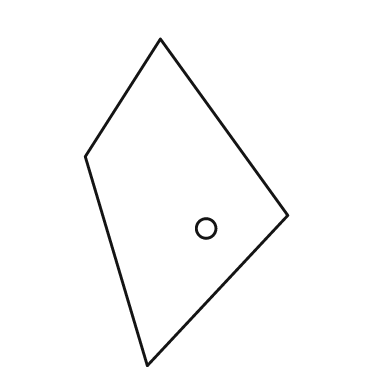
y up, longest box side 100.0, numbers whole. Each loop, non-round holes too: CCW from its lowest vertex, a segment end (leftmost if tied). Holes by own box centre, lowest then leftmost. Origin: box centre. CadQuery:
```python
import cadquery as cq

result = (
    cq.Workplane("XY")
    .moveTo(-12.0, -50.0)
    .lineTo(31.0, -4.0)
    .lineTo(-8.0, 50.0)
    .lineTo(-31.0, 14.0)
    .close()
    .moveTo(6.0, -8.0)
    .circle(3.0)
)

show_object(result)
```